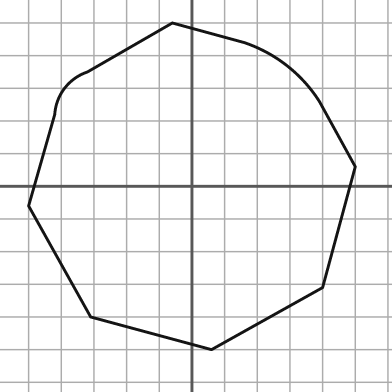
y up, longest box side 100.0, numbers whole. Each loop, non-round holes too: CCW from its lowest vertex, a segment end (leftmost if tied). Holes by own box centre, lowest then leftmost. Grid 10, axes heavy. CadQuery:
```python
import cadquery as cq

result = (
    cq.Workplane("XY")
    .moveTo(6.0, -50.0)
    .lineTo(40.0, -31.0)
    .lineTo(50.0, 6.0)
    .lineTo(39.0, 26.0)
    .threePointArc((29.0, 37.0), (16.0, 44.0))
    .lineTo(-6.0, 50.0)
    .lineTo(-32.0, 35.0)
    .threePointArc((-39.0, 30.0), (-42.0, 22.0))
    .lineTo(-50.0, -6.0)
    .lineTo(-31.0, -40.0)
    .close()
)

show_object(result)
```